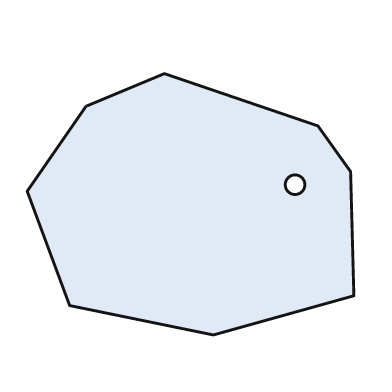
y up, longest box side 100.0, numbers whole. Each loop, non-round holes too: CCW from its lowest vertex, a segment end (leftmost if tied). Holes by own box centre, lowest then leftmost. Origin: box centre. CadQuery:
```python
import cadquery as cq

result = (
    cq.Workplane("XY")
    .moveTo(7.0, -40.0)
    .lineTo(50.0, -28.0)
    .lineTo(49.0, 10.0)
    .lineTo(39.0, 24.0)
    .lineTo(-8.0, 40.0)
    .lineTo(-32.0, 30.0)
    .lineTo(-50.0, 4.0)
    .lineTo(-37.0, -31.0)
    .close()
    .moveTo(32.0, 6.0)
    .circle(3.0)
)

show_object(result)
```